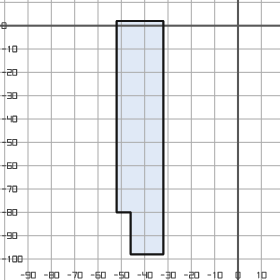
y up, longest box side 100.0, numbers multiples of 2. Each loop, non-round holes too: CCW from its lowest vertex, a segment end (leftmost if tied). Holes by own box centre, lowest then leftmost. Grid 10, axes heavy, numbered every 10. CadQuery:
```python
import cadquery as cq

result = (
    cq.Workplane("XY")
    .moveTo(-46.0, -98.0)
    .lineTo(-32.0, -98.0)
    .lineTo(-32.0, 2.0)
    .lineTo(-52.0, 2.0)
    .lineTo(-52.0, -80.0)
    .lineTo(-46.0, -80.0)
    .close()
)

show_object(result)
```